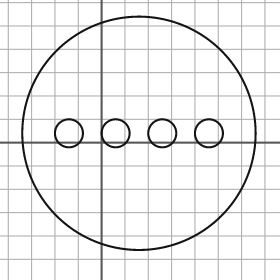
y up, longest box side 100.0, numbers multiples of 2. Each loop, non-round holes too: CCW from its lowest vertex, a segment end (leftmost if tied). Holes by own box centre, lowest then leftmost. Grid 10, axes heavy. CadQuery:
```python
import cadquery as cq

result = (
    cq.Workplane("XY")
    .moveTo(16.0, 4.0)
    .circle(50.0)
    .moveTo(-14.0, 4.0)
    .circle(6.0)
    .moveTo(6.0, 4.0)
    .circle(6.0)
    .moveTo(26.0, 4.0)
    .circle(6.0)
    .moveTo(46.0, 4.0)
    .circle(6.0)
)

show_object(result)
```